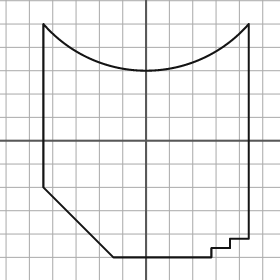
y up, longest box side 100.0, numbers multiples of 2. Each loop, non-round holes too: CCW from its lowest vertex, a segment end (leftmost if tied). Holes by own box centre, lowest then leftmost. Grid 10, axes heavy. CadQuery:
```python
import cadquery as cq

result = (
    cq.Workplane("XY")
    .moveTo(-14.0, -50.0)
    .lineTo(28.0, -50.0)
    .lineTo(28.0, -46.0)
    .lineTo(36.0, -46.0)
    .lineTo(36.0, -42.0)
    .lineTo(44.0, -42.0)
    .lineTo(44.0, 50.0)
    .threePointArc((0.0, 30.0), (-44.0, 50.0))
    .lineTo(-44.0, -20.0)
    .close()
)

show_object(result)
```